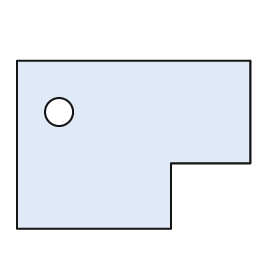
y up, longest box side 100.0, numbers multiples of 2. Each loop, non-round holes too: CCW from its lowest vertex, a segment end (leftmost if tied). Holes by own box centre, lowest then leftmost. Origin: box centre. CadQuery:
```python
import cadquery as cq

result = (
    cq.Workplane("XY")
    .moveTo(-50.0, -36.0)
    .lineTo(16.0, -36.0)
    .lineTo(16.0, -8.0)
    .lineTo(50.0, -8.0)
    .lineTo(50.0, 36.0)
    .lineTo(-50.0, 36.0)
    .close()
    .moveTo(-32.0, 14.0)
    .circle(6.0)
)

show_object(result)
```